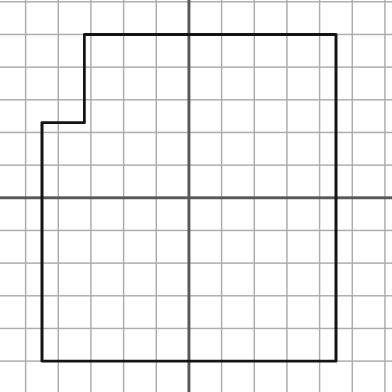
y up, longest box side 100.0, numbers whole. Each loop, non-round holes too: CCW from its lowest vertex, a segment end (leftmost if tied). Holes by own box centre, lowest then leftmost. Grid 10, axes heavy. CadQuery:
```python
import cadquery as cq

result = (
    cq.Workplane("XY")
    .moveTo(-45.0, -50.0)
    .lineTo(45.0, -50.0)
    .lineTo(45.0, 50.0)
    .lineTo(-32.0, 50.0)
    .lineTo(-32.0, 23.0)
    .lineTo(-45.0, 23.0)
    .close()
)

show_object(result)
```